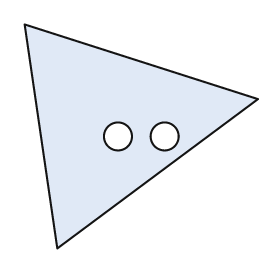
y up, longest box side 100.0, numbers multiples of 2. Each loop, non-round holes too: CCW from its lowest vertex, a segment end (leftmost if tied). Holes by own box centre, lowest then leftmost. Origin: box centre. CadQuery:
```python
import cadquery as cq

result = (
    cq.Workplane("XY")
    .moveTo(-36.0, -48.0)
    .lineTo(50.0, 16.0)
    .lineTo(-50.0, 48.0)
    .close()
    .moveTo(-10.0, 0.0)
    .circle(6.0)
    .moveTo(10.0, 0.0)
    .circle(6.0)
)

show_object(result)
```